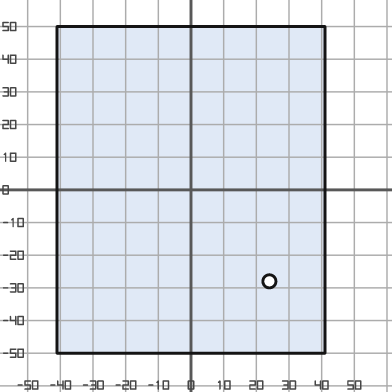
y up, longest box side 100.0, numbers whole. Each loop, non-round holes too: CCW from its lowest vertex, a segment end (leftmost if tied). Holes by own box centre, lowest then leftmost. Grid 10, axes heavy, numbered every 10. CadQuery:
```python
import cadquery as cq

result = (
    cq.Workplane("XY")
    .moveTo(-41.0, -50.0)
    .lineTo(41.0, -50.0)
    .lineTo(41.0, 50.0)
    .lineTo(-41.0, 50.0)
    .close()
    .moveTo(24.0, -28.0)
    .circle(2.0)
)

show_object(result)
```